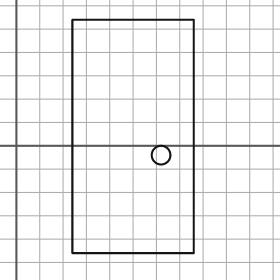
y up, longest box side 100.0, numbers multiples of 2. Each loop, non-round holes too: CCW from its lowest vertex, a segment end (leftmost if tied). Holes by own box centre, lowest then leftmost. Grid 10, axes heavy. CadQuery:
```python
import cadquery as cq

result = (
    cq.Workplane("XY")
    .moveTo(24.0, -46.0)
    .lineTo(76.0, -46.0)
    .lineTo(76.0, 54.0)
    .lineTo(24.0, 54.0)
    .close()
    .moveTo(62.0, -4.0)
    .circle(4.0)
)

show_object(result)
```